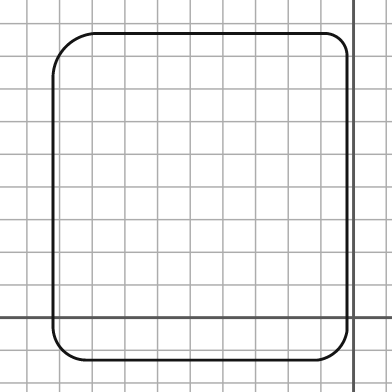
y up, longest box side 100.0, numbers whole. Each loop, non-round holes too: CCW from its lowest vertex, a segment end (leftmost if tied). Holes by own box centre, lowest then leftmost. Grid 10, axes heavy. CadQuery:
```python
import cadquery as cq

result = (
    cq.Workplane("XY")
    .moveTo(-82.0, -13.0)
    .lineTo(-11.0, -13.0)
    .threePointArc((-5.0, -10.0), (-2.0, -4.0))
    .lineTo(-2.0, 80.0)
    .threePointArc((-4.0, 85.0), (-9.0, 87.0))
    .lineTo(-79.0, 87.0)
    .threePointArc((-88.0, 83.0), (-92.0, 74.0))
    .lineTo(-92.0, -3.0)
    .threePointArc((-89.0, -10.0), (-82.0, -13.0))
    .close()
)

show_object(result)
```